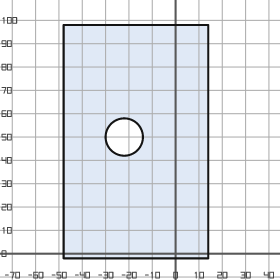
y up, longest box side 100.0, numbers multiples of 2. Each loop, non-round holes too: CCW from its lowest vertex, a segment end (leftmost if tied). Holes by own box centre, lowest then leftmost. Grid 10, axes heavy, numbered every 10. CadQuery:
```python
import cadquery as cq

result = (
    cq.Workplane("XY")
    .moveTo(-48.0, -2.0)
    .lineTo(14.0, -2.0)
    .lineTo(14.0, 98.0)
    .lineTo(-48.0, 98.0)
    .close()
    .moveTo(-22.0, 50.0)
    .circle(8.0)
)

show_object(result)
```